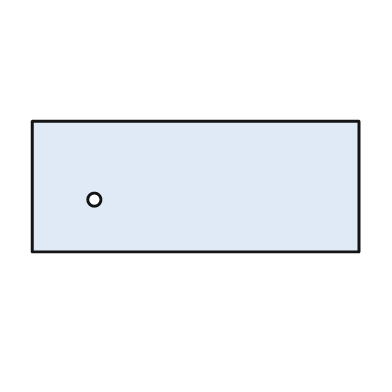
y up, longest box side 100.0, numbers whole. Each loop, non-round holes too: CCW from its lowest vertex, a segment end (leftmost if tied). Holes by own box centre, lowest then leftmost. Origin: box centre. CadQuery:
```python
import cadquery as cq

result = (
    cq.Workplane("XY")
    .moveTo(-50.0, -20.0)
    .lineTo(50.0, -20.0)
    .lineTo(50.0, 20.0)
    .lineTo(-50.0, 20.0)
    .close()
    .moveTo(-31.0, -4.0)
    .circle(2.0)
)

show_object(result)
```